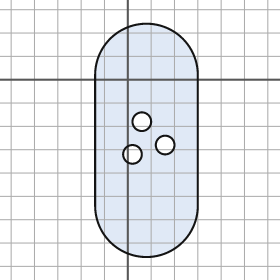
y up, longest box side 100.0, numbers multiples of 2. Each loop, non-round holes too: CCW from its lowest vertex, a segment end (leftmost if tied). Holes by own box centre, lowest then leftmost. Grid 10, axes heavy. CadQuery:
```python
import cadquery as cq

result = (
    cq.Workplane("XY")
    .moveTo(-14.0, -54.0)
    .threePointArc((8.0, -76.0), (30.0, -54.0))
    .lineTo(30.0, 2.0)
    .threePointArc((8.0, 24.0), (-14.0, 2.0))
    .close()
    .moveTo(2.0, -32.0)
    .circle(4.0)
    .moveTo(16.0, -28.0)
    .circle(4.0)
    .moveTo(6.0, -18.0)
    .circle(4.0)
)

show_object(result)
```